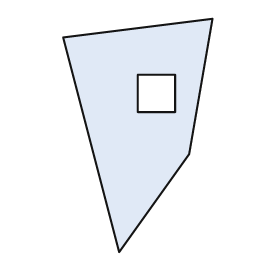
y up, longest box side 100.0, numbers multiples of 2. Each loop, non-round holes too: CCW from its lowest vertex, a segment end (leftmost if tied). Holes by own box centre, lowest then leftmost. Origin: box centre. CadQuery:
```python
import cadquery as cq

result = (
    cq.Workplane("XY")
    .moveTo(-8.0, -50.0)
    .lineTo(22.0, -8.0)
    .lineTo(32.0, 50.0)
    .lineTo(-32.0, 42.0)
    .close()
    .moveTo(0.0, 10.0)
    .lineTo(16.0, 10.0)
    .lineTo(16.0, 26.0)
    .lineTo(0.0, 26.0)
    .close()
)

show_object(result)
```